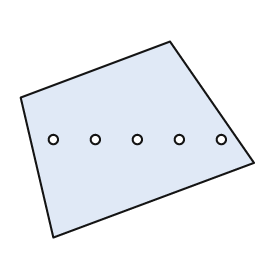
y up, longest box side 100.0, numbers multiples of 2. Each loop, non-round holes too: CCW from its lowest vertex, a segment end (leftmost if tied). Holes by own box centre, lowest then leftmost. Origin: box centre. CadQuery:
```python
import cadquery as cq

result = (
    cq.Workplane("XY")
    .moveTo(-36.0, -42.0)
    .lineTo(50.0, -10.0)
    .lineTo(14.0, 42.0)
    .lineTo(-50.0, 18.0)
    .close()
    .moveTo(-36.0, 0.0)
    .circle(2.0)
    .moveTo(-18.0, 0.0)
    .circle(2.0)
    .moveTo(0.0, 0.0)
    .circle(2.0)
    .moveTo(18.0, 0.0)
    .circle(2.0)
    .moveTo(36.0, 0.0)
    .circle(2.0)
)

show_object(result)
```